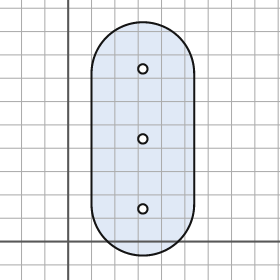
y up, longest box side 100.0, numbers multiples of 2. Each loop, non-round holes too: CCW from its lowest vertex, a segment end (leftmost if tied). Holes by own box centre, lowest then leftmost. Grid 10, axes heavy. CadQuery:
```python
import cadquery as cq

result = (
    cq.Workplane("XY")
    .moveTo(10.0, 16.0)
    .threePointArc((32.0, -6.0), (54.0, 16.0))
    .lineTo(54.0, 72.0)
    .threePointArc((32.0, 94.0), (10.0, 72.0))
    .close()
    .moveTo(32.0, 14.0)
    .circle(2.0)
    .moveTo(32.0, 44.0)
    .circle(2.0)
    .moveTo(32.0, 74.0)
    .circle(2.0)
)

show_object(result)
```